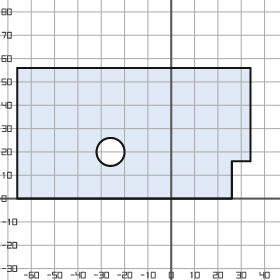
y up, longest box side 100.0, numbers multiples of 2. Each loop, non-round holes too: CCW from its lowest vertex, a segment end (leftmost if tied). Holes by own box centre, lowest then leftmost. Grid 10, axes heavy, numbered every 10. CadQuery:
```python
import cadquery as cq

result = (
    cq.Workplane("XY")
    .moveTo(-66.0, 0.0)
    .lineTo(26.0, 0.0)
    .lineTo(26.0, 16.0)
    .lineTo(34.0, 16.0)
    .lineTo(34.0, 56.0)
    .lineTo(-66.0, 56.0)
    .close()
    .moveTo(-26.0, 20.0)
    .circle(6.0)
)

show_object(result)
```